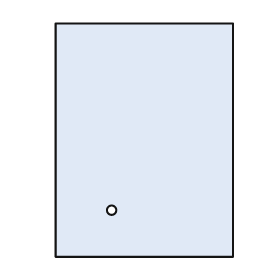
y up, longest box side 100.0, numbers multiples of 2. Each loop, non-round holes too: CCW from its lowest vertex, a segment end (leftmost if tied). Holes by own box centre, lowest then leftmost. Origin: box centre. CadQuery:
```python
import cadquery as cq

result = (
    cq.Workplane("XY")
    .moveTo(-38.0, -50.0)
    .lineTo(38.0, -50.0)
    .lineTo(38.0, 50.0)
    .lineTo(-38.0, 50.0)
    .close()
    .moveTo(-14.0, -30.0)
    .circle(2.0)
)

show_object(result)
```